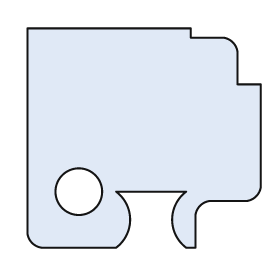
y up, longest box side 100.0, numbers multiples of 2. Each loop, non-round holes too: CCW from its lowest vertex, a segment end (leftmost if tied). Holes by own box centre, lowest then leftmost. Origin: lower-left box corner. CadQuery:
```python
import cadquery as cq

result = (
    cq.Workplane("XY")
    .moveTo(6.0, 0.0)
    .lineTo(38.0, 0.0)
    .threePointArc((44.0, 12.0), (38.0, 24.0))
    .lineTo(68.0, 24.0)
    .threePointArc((62.0, 12.0), (68.0, 0.0))
    .lineTo(72.0, 0.0)
    .lineTo(72.0, 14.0)
    .threePointArc((74.0, 18.0), (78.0, 20.0))
    .lineTo(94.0, 20.0)
    .threePointArc((98.0, 22.0), (100.0, 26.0))
    .lineTo(100.0, 70.0)
    .lineTo(90.0, 70.0)
    .lineTo(90.0, 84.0)
    .threePointArc((88.0, 88.0), (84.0, 90.0))
    .lineTo(70.0, 90.0)
    .lineTo(70.0, 94.0)
    .lineTo(0.0, 94.0)
    .lineTo(0.0, 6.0)
    .threePointArc((2.0, 2.0), (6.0, 0.0))
    .close()
    .moveTo(22.0, 24.0)
    .circle(10.0)
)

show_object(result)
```